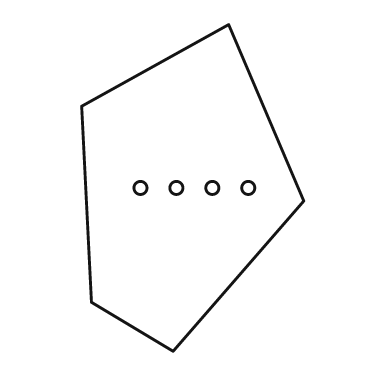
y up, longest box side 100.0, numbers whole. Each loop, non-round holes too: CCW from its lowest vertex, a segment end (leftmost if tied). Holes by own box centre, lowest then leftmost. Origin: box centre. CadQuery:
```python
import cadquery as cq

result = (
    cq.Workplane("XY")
    .moveTo(-6.0, -50.0)
    .lineTo(34.0, -4.0)
    .lineTo(11.0, 50.0)
    .lineTo(-34.0, 25.0)
    .lineTo(-31.0, -35.0)
    .close()
    .moveTo(-16.0, 0.0)
    .circle(2.0)
    .moveTo(-5.0, 0.0)
    .circle(2.0)
    .moveTo(6.0, 0.0)
    .circle(2.0)
    .moveTo(17.0, 0.0)
    .circle(2.0)
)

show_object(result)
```